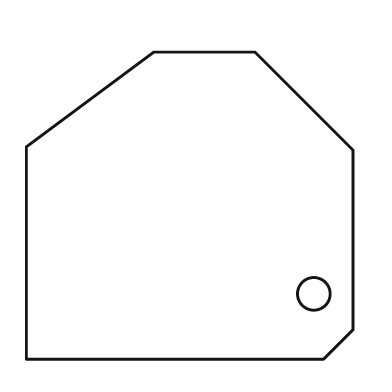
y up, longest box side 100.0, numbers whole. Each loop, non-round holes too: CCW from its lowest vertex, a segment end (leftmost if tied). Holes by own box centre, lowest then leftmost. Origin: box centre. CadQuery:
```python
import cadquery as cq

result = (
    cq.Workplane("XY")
    .moveTo(-50.0, -47.0)
    .lineTo(41.0, -47.0)
    .lineTo(50.0, -38.0)
    .lineTo(50.0, 17.0)
    .lineTo(20.0, 47.0)
    .lineTo(-11.0, 47.0)
    .lineTo(-50.0, 18.0)
    .close()
    .moveTo(38.0, -27.0)
    .circle(5.0)
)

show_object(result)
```